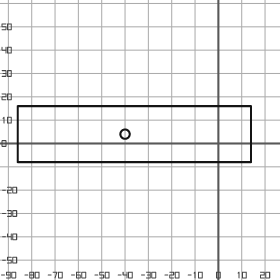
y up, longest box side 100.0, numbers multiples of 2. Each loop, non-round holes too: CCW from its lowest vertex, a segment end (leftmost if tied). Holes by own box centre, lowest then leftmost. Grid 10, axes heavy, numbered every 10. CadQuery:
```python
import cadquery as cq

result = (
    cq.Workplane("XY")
    .moveTo(-86.0, -8.0)
    .lineTo(14.0, -8.0)
    .lineTo(14.0, 16.0)
    .lineTo(-86.0, 16.0)
    .close()
    .moveTo(-40.0, 4.0)
    .circle(2.0)
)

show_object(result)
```